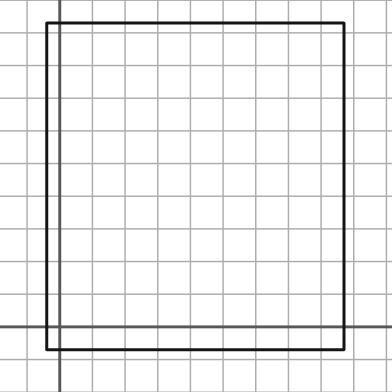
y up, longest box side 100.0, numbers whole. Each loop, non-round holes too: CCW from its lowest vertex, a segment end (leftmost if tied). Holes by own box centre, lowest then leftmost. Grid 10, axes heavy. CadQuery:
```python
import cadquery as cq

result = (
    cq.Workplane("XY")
    .moveTo(-4.0, -7.0)
    .lineTo(87.0, -7.0)
    .lineTo(87.0, 93.0)
    .lineTo(-4.0, 93.0)
    .close()
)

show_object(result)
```